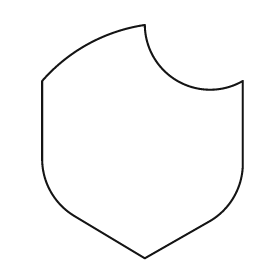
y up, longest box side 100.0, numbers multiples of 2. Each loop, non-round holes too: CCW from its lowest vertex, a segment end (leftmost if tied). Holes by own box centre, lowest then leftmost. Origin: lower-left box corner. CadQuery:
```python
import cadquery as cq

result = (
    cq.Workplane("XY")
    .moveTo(44.0, 0.0)
    .lineTo(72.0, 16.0)
    .threePointArc((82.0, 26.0), (86.0, 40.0))
    .lineTo(86.0, 76.0)
    .threePointArc((58.0, 76.0), (44.0, 100.0))
    .threePointArc((20.0, 92.0), (0.0, 76.0))
    .lineTo(0.0, 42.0)
    .threePointArc((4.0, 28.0), (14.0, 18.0))
    .close()
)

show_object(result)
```